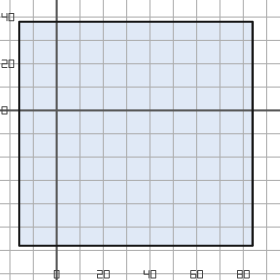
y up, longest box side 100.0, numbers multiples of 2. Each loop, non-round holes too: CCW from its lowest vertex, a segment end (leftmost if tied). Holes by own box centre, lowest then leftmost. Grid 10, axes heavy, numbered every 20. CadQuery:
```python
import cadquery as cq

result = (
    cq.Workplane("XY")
    .moveTo(-16.0, -58.0)
    .lineTo(84.0, -58.0)
    .lineTo(84.0, 38.0)
    .lineTo(-16.0, 38.0)
    .close()
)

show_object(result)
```